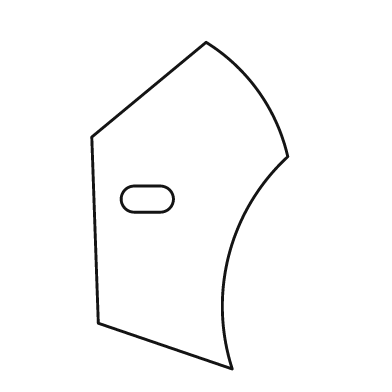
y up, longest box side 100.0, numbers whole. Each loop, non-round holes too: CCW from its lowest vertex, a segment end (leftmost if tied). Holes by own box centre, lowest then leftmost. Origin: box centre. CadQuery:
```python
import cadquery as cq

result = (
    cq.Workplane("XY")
    .moveTo(13.0, -50.0)
    .threePointArc((12.0, -15.0), (30.0, 15.0))
    .threePointArc((21.0, 35.0), (5.0, 50.0))
    .lineTo(-30.0, 21.0)
    .lineTo(-28.0, -36.0)
    .close()
    .moveTo(-17.0, -2.0)
    .lineTo(-9.0, -2.0)
    .threePointArc((-5.0, 2.0), (-9.0, 6.0))
    .lineTo(-17.0, 6.0)
    .threePointArc((-21.0, 2.0), (-17.0, -2.0))
    .close()
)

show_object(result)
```